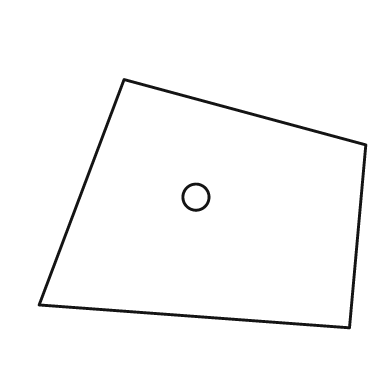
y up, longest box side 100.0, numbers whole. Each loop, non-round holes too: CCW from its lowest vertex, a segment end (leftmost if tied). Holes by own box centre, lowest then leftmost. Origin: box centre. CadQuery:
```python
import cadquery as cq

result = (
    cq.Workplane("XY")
    .moveTo(45.0, -38.0)
    .lineTo(50.0, 18.0)
    .lineTo(-24.0, 38.0)
    .lineTo(-50.0, -31.0)
    .close()
    .moveTo(-2.0, 2.0)
    .circle(4.0)
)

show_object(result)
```